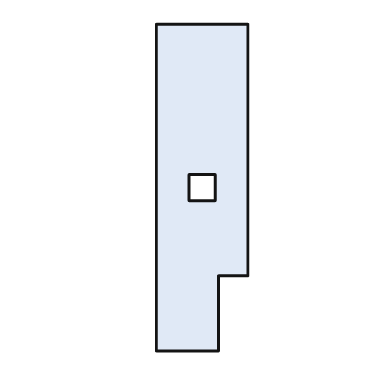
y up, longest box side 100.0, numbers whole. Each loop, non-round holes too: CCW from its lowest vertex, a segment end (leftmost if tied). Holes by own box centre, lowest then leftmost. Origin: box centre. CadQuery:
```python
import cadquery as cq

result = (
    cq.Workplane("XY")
    .moveTo(-14.0, -50.0)
    .lineTo(5.0, -50.0)
    .lineTo(5.0, -27.0)
    .lineTo(14.0, -27.0)
    .lineTo(14.0, 50.0)
    .lineTo(-14.0, 50.0)
    .close()
    .moveTo(-4.0, -4.0)
    .lineTo(4.0, -4.0)
    .lineTo(4.0, 4.0)
    .lineTo(-4.0, 4.0)
    .close()
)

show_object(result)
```